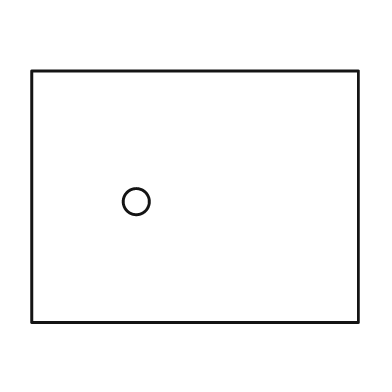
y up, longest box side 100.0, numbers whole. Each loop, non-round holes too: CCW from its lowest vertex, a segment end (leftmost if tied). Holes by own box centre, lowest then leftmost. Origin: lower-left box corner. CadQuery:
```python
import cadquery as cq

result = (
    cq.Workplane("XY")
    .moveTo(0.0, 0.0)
    .lineTo(100.0, 0.0)
    .lineTo(100.0, 77.0)
    .lineTo(0.0, 77.0)
    .close()
    .moveTo(32.0, 37.0)
    .circle(4.0)
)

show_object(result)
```